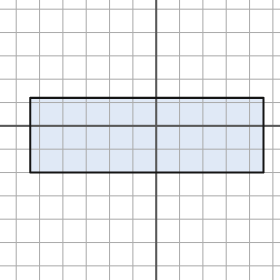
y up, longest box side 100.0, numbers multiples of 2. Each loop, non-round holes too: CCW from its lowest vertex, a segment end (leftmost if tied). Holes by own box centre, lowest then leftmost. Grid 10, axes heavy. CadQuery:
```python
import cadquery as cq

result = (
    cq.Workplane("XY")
    .moveTo(-54.0, -20.0)
    .lineTo(46.0, -20.0)
    .lineTo(46.0, 12.0)
    .lineTo(-54.0, 12.0)
    .close()
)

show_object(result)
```